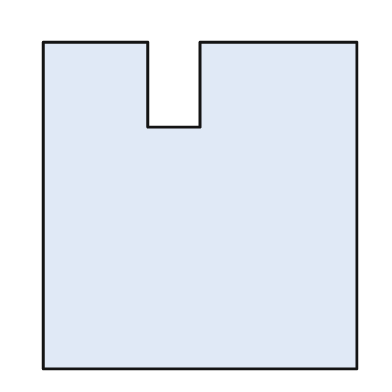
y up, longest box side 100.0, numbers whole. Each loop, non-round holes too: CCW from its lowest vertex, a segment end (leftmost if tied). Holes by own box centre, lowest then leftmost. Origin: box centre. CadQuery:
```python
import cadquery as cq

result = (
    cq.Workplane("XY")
    .moveTo(-48.0, -50.0)
    .lineTo(48.0, -50.0)
    .lineTo(48.0, 50.0)
    .lineTo(0.0, 50.0)
    .lineTo(0.0, 24.0)
    .lineTo(-16.0, 24.0)
    .lineTo(-16.0, 50.0)
    .lineTo(-48.0, 50.0)
    .close()
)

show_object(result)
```